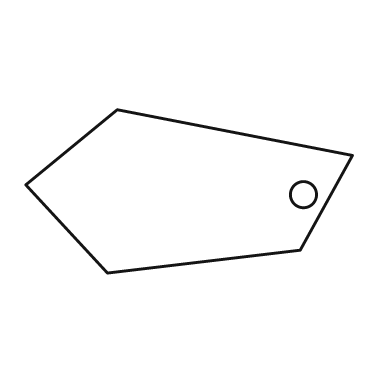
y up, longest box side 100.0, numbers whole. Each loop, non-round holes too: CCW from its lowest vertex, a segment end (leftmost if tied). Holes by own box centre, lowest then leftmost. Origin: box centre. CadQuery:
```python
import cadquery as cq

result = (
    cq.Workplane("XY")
    .moveTo(-25.0, -25.0)
    .lineTo(34.0, -18.0)
    .lineTo(50.0, 11.0)
    .lineTo(-22.0, 25.0)
    .lineTo(-50.0, 2.0)
    .close()
    .moveTo(35.0, -1.0)
    .circle(4.0)
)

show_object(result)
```